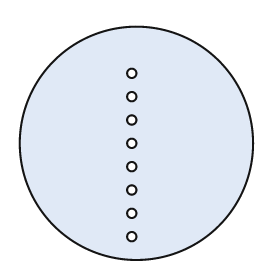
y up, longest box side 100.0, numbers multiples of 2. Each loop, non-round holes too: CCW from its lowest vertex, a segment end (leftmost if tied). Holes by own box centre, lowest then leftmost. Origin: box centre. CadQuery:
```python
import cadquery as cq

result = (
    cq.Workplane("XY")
    .moveTo(0.0, 0.0)
    .circle(50.0)
    .moveTo(-2.0, -40.0)
    .circle(2.0)
    .moveTo(-2.0, -30.0)
    .circle(2.0)
    .moveTo(-2.0, -20.0)
    .circle(2.0)
    .moveTo(-2.0, -10.0)
    .circle(2.0)
    .moveTo(-2.0, 0.0)
    .circle(2.0)
    .moveTo(-2.0, 10.0)
    .circle(2.0)
    .moveTo(-2.0, 20.0)
    .circle(2.0)
    .moveTo(-2.0, 30.0)
    .circle(2.0)
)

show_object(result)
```